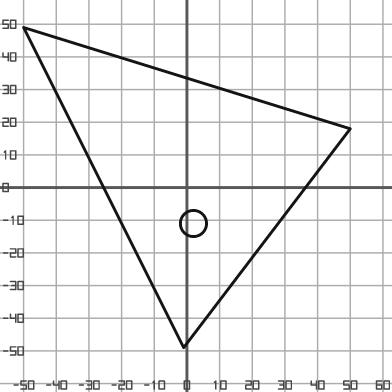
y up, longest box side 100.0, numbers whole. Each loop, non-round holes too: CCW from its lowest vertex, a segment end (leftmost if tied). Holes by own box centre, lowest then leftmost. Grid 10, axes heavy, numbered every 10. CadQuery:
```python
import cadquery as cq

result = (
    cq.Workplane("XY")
    .moveTo(-1.0, -49.0)
    .lineTo(50.0, 18.0)
    .lineTo(-50.0, 49.0)
    .close()
    .moveTo(2.0, -11.0)
    .circle(4.0)
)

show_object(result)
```